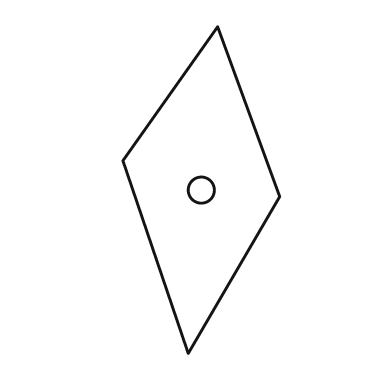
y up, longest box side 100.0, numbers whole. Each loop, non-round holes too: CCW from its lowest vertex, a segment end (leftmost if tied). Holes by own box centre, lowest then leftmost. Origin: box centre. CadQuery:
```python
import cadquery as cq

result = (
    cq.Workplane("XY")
    .moveTo(-4.0, -50.0)
    .lineTo(24.0, -2.0)
    .lineTo(5.0, 50.0)
    .lineTo(-24.0, 9.0)
    .close()
    .moveTo(0.0, 0.0)
    .circle(4.0)
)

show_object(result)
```